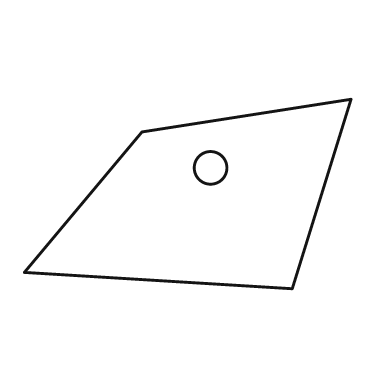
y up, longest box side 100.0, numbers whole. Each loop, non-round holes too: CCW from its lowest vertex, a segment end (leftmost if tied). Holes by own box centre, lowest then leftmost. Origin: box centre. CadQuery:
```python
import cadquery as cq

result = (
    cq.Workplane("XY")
    .moveTo(32.0, -29.0)
    .lineTo(50.0, 29.0)
    .lineTo(-14.0, 19.0)
    .lineTo(-50.0, -24.0)
    .close()
    .moveTo(7.0, 8.0)
    .circle(5.0)
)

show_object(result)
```